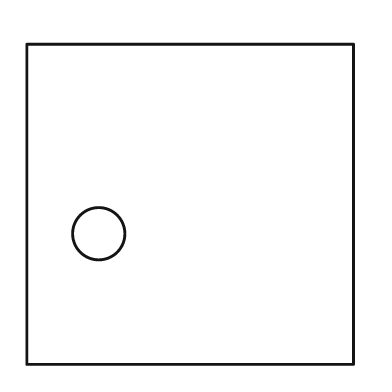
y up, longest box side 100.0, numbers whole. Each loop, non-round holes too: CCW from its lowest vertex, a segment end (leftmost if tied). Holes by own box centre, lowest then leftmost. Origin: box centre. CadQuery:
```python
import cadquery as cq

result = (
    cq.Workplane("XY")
    .moveTo(-50.0, -49.0)
    .lineTo(50.0, -49.0)
    .lineTo(50.0, 49.0)
    .lineTo(-50.0, 49.0)
    .close()
    .moveTo(-28.0, -9.0)
    .circle(8.0)
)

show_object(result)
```